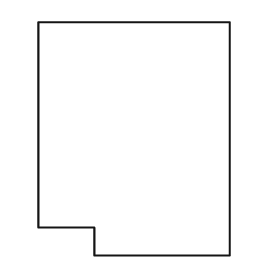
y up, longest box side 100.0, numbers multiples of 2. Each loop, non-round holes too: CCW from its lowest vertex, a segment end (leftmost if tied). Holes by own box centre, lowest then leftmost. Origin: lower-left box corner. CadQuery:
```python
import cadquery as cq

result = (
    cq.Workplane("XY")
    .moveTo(24.0, 0.0)
    .lineTo(82.0, 0.0)
    .lineTo(82.0, 100.0)
    .lineTo(0.0, 100.0)
    .lineTo(0.0, 12.0)
    .lineTo(24.0, 12.0)
    .close()
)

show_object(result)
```